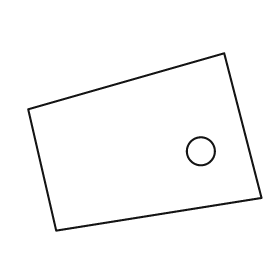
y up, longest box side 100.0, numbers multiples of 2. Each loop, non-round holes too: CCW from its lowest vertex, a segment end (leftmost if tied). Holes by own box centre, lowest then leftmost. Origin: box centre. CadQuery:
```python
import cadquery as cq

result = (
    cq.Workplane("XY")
    .moveTo(-38.0, -38.0)
    .lineTo(50.0, -24.0)
    .lineTo(34.0, 38.0)
    .lineTo(-50.0, 14.0)
    .close()
    .moveTo(24.0, -4.0)
    .circle(6.0)
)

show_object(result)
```